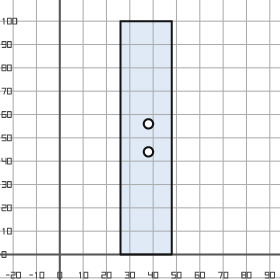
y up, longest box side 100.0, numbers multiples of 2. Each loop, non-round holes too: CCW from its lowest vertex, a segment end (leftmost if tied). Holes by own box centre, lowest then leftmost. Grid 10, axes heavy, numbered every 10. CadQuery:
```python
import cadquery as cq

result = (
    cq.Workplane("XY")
    .moveTo(26.0, 0.0)
    .lineTo(48.0, 0.0)
    .lineTo(48.0, 100.0)
    .lineTo(26.0, 100.0)
    .close()
    .moveTo(38.0, 44.0)
    .circle(2.0)
    .moveTo(38.0, 56.0)
    .circle(2.0)
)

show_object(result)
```